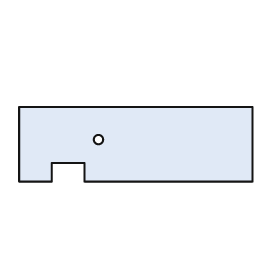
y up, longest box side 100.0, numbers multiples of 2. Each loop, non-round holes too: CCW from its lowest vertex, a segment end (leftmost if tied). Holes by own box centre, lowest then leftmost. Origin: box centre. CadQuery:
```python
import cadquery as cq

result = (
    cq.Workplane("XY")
    .moveTo(-50.0, -16.0)
    .lineTo(-36.0, -16.0)
    .lineTo(-36.0, -8.0)
    .lineTo(-22.0, -8.0)
    .lineTo(-22.0, -16.0)
    .lineTo(50.0, -16.0)
    .lineTo(50.0, 16.0)
    .lineTo(-50.0, 16.0)
    .close()
    .moveTo(-16.0, 2.0)
    .circle(2.0)
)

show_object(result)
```